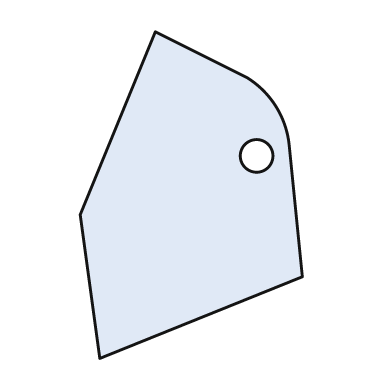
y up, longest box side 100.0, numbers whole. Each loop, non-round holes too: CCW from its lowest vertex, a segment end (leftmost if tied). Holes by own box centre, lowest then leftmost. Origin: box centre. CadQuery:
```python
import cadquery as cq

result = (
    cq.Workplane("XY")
    .moveTo(-28.0, -50.0)
    .lineTo(34.0, -25.0)
    .lineTo(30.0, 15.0)
    .threePointArc((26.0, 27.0), (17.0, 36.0))
    .lineTo(-11.0, 50.0)
    .lineTo(-34.0, -6.0)
    .close()
    .moveTo(20.0, 12.0)
    .circle(5.0)
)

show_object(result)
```